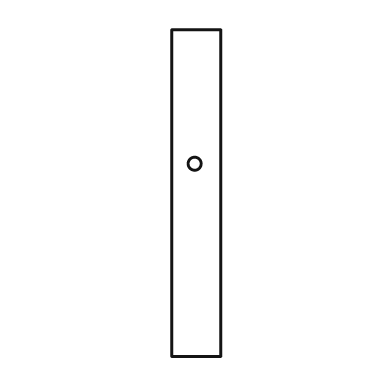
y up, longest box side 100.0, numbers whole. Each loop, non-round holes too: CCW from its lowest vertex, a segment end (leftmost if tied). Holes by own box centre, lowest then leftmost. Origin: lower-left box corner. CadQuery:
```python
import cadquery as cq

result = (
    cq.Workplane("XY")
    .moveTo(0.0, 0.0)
    .lineTo(15.0, 0.0)
    .lineTo(15.0, 100.0)
    .lineTo(0.0, 100.0)
    .close()
    .moveTo(7.0, 59.0)
    .circle(2.0)
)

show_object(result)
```